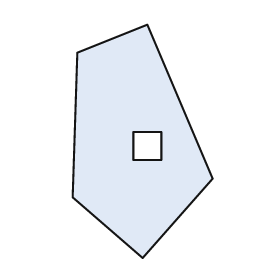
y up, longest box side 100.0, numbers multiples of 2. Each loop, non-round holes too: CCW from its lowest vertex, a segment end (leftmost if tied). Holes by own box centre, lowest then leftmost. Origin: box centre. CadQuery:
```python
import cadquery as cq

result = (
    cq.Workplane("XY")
    .moveTo(0.0, -50.0)
    .lineTo(30.0, -16.0)
    .lineTo(2.0, 50.0)
    .lineTo(-28.0, 38.0)
    .lineTo(-30.0, -24.0)
    .close()
    .moveTo(-4.0, -8.0)
    .lineTo(8.0, -8.0)
    .lineTo(8.0, 4.0)
    .lineTo(-4.0, 4.0)
    .close()
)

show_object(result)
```